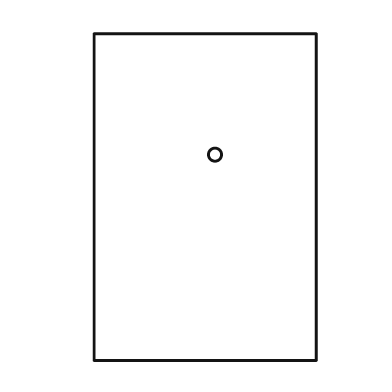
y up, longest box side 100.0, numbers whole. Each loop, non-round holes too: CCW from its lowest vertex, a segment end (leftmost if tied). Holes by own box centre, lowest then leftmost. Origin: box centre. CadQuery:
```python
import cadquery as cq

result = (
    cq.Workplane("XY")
    .moveTo(-34.0, -50.0)
    .lineTo(34.0, -50.0)
    .lineTo(34.0, 50.0)
    .lineTo(-34.0, 50.0)
    .close()
    .moveTo(3.0, 13.0)
    .circle(2.0)
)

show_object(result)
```